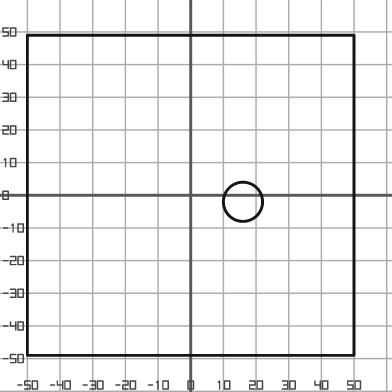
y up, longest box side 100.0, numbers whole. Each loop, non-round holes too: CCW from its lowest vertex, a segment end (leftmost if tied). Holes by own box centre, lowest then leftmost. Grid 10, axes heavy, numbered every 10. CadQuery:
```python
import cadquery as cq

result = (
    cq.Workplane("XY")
    .moveTo(-50.0, -49.0)
    .lineTo(50.0, -49.0)
    .lineTo(50.0, 49.0)
    .lineTo(-50.0, 49.0)
    .close()
    .moveTo(16.0, -2.0)
    .circle(6.0)
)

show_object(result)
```